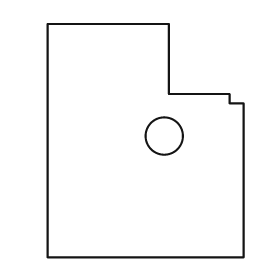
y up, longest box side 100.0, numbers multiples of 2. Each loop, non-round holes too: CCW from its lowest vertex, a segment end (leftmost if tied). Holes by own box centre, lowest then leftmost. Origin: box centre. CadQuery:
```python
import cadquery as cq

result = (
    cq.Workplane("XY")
    .moveTo(-42.0, -50.0)
    .lineTo(42.0, -50.0)
    .lineTo(42.0, 16.0)
    .lineTo(36.0, 16.0)
    .lineTo(36.0, 20.0)
    .lineTo(10.0, 20.0)
    .lineTo(10.0, 50.0)
    .lineTo(-42.0, 50.0)
    .close()
    .moveTo(8.0, 2.0)
    .circle(8.0)
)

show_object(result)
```